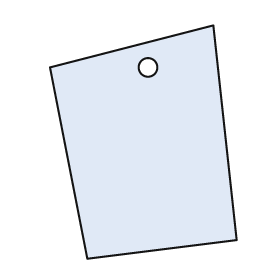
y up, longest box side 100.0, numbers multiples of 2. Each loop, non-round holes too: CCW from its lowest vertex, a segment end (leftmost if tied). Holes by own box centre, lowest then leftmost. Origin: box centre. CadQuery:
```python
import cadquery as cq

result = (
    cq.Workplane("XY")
    .moveTo(-24.0, -50.0)
    .lineTo(40.0, -42.0)
    .lineTo(30.0, 50.0)
    .lineTo(-40.0, 32.0)
    .close()
    .moveTo(2.0, 32.0)
    .circle(4.0)
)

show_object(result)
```